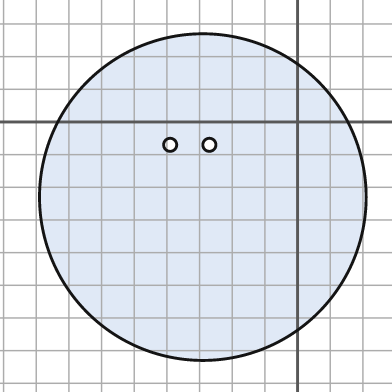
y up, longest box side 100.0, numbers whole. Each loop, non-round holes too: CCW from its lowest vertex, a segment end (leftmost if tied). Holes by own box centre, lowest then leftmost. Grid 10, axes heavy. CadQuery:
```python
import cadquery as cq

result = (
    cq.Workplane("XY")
    .moveTo(-29.0, -23.0)
    .circle(50.0)
    .moveTo(-39.0, -7.0)
    .circle(2.0)
    .moveTo(-27.0, -7.0)
    .circle(2.0)
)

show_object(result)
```